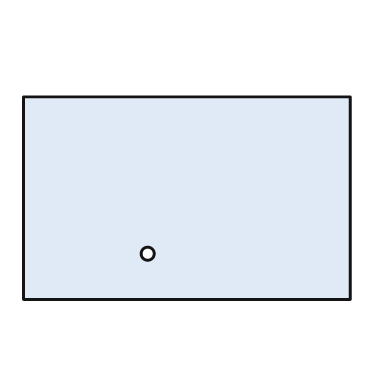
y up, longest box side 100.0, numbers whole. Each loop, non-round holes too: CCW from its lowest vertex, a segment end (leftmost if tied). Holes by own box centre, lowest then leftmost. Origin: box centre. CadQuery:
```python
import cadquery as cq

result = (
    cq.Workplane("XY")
    .moveTo(-50.0, -31.0)
    .lineTo(50.0, -31.0)
    .lineTo(50.0, 31.0)
    .lineTo(-50.0, 31.0)
    .close()
    .moveTo(-12.0, -17.0)
    .circle(2.0)
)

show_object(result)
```